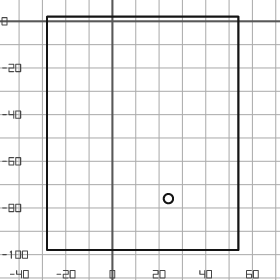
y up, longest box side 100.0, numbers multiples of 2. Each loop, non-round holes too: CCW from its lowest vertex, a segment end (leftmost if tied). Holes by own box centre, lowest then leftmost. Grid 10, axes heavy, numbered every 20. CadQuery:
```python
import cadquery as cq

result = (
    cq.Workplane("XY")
    .moveTo(-28.0, -98.0)
    .lineTo(54.0, -98.0)
    .lineTo(54.0, 2.0)
    .lineTo(-28.0, 2.0)
    .close()
    .moveTo(24.0, -76.0)
    .circle(2.0)
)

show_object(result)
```